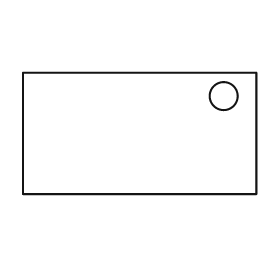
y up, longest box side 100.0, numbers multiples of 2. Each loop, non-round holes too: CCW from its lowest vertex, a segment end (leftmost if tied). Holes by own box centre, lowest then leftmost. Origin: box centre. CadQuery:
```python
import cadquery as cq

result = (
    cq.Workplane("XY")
    .moveTo(-50.0, -26.0)
    .lineTo(50.0, -26.0)
    .lineTo(50.0, 26.0)
    .lineTo(-50.0, 26.0)
    .close()
    .moveTo(36.0, 16.0)
    .circle(6.0)
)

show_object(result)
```